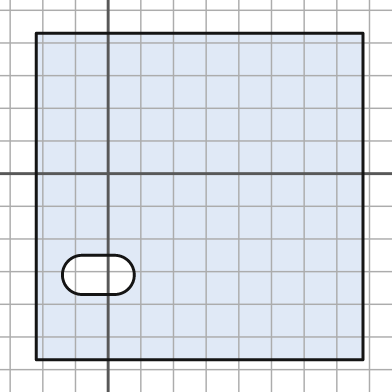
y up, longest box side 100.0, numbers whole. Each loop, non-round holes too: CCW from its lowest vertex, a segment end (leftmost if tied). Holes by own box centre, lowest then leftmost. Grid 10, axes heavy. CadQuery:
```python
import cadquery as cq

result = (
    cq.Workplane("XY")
    .moveTo(-22.0, -57.0)
    .lineTo(78.0, -57.0)
    .lineTo(78.0, 43.0)
    .lineTo(-22.0, 43.0)
    .close()
    .moveTo(-8.0, -37.0)
    .lineTo(2.0, -37.0)
    .threePointArc((8.0, -31.0), (2.0, -25.0))
    .lineTo(-8.0, -25.0)
    .threePointArc((-14.0, -31.0), (-8.0, -37.0))
    .close()
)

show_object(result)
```